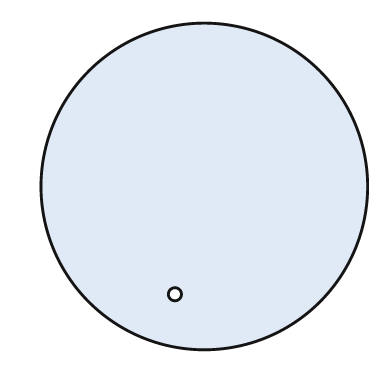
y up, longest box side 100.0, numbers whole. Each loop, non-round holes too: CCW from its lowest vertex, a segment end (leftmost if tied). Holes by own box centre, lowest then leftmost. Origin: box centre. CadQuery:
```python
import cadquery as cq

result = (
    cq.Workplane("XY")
    .moveTo(0.0, 0.0)
    .circle(50.0)
    .moveTo(-9.0, -33.0)
    .circle(2.0)
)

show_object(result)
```